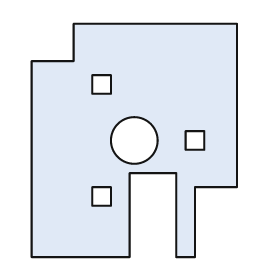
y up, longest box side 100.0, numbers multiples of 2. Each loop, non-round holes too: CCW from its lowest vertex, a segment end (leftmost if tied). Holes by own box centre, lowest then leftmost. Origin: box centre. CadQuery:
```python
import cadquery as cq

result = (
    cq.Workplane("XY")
    .moveTo(-44.0, -50.0)
    .lineTo(-2.0, -50.0)
    .lineTo(-2.0, -14.0)
    .lineTo(18.0, -14.0)
    .lineTo(18.0, -50.0)
    .lineTo(26.0, -50.0)
    .lineTo(26.0, -20.0)
    .lineTo(44.0, -20.0)
    .lineTo(44.0, 50.0)
    .lineTo(-26.0, 50.0)
    .lineTo(-26.0, 34.0)
    .lineTo(-44.0, 34.0)
    .close()
    .moveTo(-18.0, -28.0)
    .lineTo(-10.0, -28.0)
    .lineTo(-10.0, -20.0)
    .lineTo(-18.0, -20.0)
    .close()
    .moveTo(0.0, 0.0)
    .circle(10.0)
    .moveTo(22.0, -4.0)
    .lineTo(30.0, -4.0)
    .lineTo(30.0, 4.0)
    .lineTo(22.0, 4.0)
    .close()
    .moveTo(-18.0, 20.0)
    .lineTo(-10.0, 20.0)
    .lineTo(-10.0, 28.0)
    .lineTo(-18.0, 28.0)
    .close()
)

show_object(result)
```